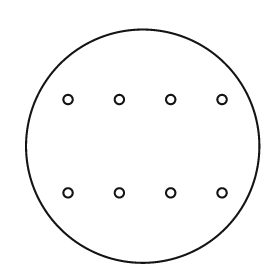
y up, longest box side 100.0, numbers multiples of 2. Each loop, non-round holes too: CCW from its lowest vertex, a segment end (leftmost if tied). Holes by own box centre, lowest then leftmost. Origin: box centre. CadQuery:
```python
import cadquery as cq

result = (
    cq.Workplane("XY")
    .moveTo(0.0, 0.0)
    .circle(50.0)
    .moveTo(-32.0, -20.0)
    .circle(2.0)
    .moveTo(-10.0, -20.0)
    .circle(2.0)
    .moveTo(12.0, -20.0)
    .circle(2.0)
    .moveTo(34.0, -20.0)
    .circle(2.0)
    .moveTo(-32.0, 20.0)
    .circle(2.0)
    .moveTo(-10.0, 20.0)
    .circle(2.0)
    .moveTo(12.0, 20.0)
    .circle(2.0)
    .moveTo(34.0, 20.0)
    .circle(2.0)
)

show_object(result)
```